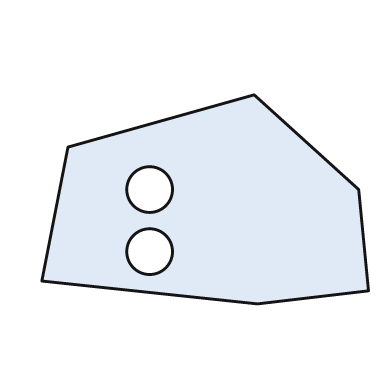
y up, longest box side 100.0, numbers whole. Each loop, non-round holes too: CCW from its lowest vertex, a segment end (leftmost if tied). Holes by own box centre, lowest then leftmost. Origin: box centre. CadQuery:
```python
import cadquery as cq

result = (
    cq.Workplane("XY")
    .moveTo(16.0, -32.0)
    .lineTo(50.0, -28.0)
    .lineTo(47.0, 3.0)
    .lineTo(15.0, 32.0)
    .lineTo(-42.0, 16.0)
    .lineTo(-50.0, -25.0)
    .close()
    .moveTo(-17.0, -16.0)
    .circle(7.0)
    .moveTo(-17.0, 3.0)
    .circle(7.0)
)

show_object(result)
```